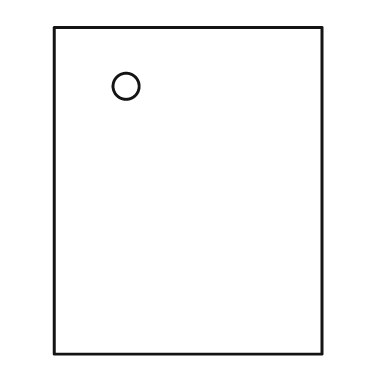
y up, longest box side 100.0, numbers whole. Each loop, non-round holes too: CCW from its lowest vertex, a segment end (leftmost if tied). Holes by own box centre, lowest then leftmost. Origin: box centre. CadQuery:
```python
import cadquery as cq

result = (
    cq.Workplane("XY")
    .moveTo(-41.0, -50.0)
    .lineTo(41.0, -50.0)
    .lineTo(41.0, 50.0)
    .lineTo(-41.0, 50.0)
    .close()
    .moveTo(-19.0, 32.0)
    .circle(4.0)
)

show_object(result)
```